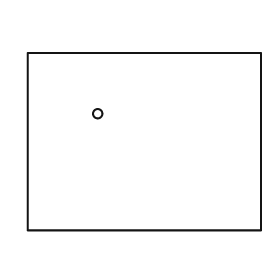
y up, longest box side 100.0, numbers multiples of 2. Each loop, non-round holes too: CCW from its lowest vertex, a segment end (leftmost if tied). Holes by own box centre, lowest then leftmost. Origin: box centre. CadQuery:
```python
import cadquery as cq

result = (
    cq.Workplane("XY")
    .moveTo(-50.0, -38.0)
    .lineTo(50.0, -38.0)
    .lineTo(50.0, 38.0)
    .lineTo(-50.0, 38.0)
    .close()
    .moveTo(-20.0, 12.0)
    .circle(2.0)
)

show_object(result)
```